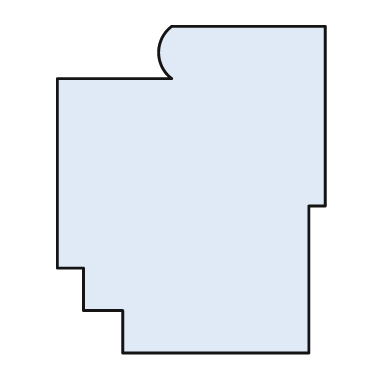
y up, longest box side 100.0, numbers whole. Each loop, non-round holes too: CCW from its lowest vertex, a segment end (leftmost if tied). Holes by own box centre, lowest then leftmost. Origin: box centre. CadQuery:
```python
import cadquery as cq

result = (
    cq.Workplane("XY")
    .moveTo(-21.0, -50.0)
    .lineTo(36.0, -50.0)
    .lineTo(36.0, -5.0)
    .lineTo(41.0, -5.0)
    .lineTo(41.0, 50.0)
    .lineTo(-6.0, 50.0)
    .threePointArc((-10.0, 42.0), (-6.0, 34.0))
    .lineTo(-41.0, 34.0)
    .lineTo(-41.0, -24.0)
    .lineTo(-33.0, -24.0)
    .lineTo(-33.0, -37.0)
    .lineTo(-21.0, -37.0)
    .close()
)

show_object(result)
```